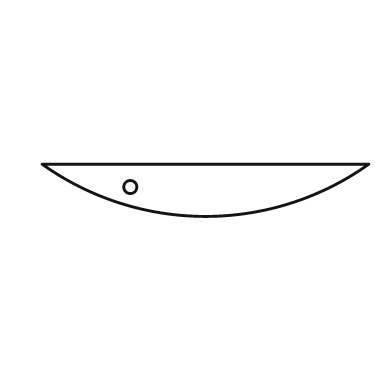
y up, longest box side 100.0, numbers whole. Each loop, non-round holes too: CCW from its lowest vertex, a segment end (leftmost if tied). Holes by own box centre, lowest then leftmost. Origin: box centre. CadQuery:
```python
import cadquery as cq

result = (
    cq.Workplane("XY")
    .moveTo(-50.0, 8.0)
    .threePointArc((0.0, -8.0), (50.0, 8.0))
    .close()
    .moveTo(-23.0, 1.0)
    .circle(2.0)
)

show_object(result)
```